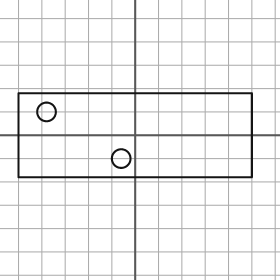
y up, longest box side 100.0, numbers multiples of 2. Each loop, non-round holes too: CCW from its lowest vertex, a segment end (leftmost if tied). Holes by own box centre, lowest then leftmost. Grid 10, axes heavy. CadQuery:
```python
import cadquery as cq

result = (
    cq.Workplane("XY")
    .moveTo(-50.0, -18.0)
    .lineTo(50.0, -18.0)
    .lineTo(50.0, 18.0)
    .lineTo(-50.0, 18.0)
    .close()
    .moveTo(-6.0, -10.0)
    .circle(4.0)
    .moveTo(-38.0, 10.0)
    .circle(4.0)
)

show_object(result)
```